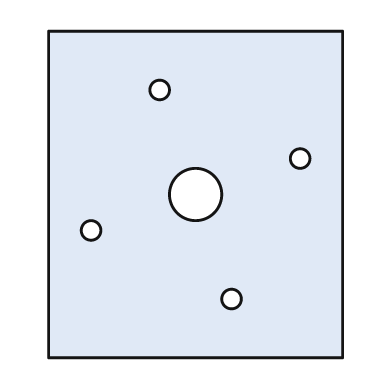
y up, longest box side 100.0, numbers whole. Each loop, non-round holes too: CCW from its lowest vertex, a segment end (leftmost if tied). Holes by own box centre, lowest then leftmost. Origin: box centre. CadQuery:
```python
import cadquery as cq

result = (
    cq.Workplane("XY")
    .moveTo(-45.0, -50.0)
    .lineTo(45.0, -50.0)
    .lineTo(45.0, 50.0)
    .lineTo(-45.0, 50.0)
    .close()
    .moveTo(11.0, -32.0)
    .circle(3.0)
    .moveTo(-32.0, -11.0)
    .circle(3.0)
    .moveTo(0.0, 0.0)
    .circle(8.0)
    .moveTo(32.0, 11.0)
    .circle(3.0)
    .moveTo(-11.0, 32.0)
    .circle(3.0)
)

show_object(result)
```